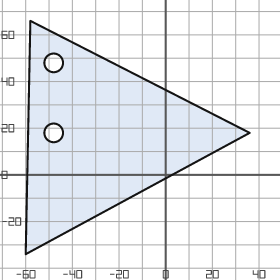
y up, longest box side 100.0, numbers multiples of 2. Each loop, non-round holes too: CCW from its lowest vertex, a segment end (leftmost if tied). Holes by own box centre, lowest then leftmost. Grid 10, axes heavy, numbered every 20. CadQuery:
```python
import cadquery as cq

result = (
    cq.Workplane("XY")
    .moveTo(-60.0, -34.0)
    .lineTo(36.0, 18.0)
    .lineTo(-58.0, 66.0)
    .close()
    .moveTo(-48.0, 18.0)
    .circle(4.0)
    .moveTo(-48.0, 48.0)
    .circle(4.0)
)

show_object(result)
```